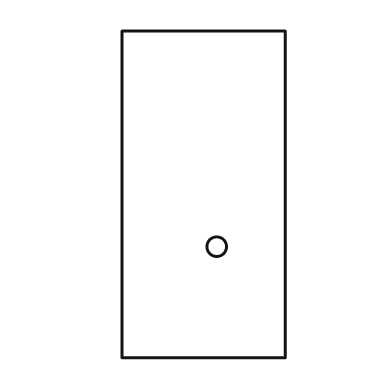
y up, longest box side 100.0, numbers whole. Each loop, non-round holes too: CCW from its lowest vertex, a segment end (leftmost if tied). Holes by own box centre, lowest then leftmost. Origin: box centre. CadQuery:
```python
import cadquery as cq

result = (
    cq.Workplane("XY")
    .moveTo(-25.0, -50.0)
    .lineTo(25.0, -50.0)
    .lineTo(25.0, 50.0)
    .lineTo(-25.0, 50.0)
    .close()
    .moveTo(4.0, -16.0)
    .circle(3.0)
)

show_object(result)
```